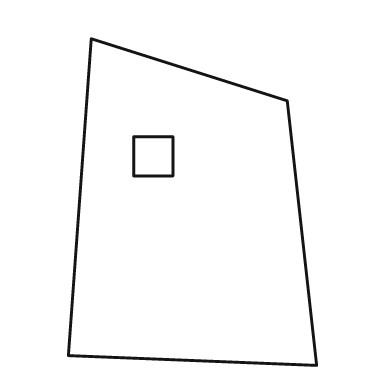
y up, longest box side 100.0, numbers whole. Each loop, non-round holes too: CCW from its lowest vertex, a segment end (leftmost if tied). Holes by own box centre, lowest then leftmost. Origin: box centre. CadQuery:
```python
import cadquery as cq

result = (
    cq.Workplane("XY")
    .moveTo(38.0, -50.0)
    .lineTo(29.0, 31.0)
    .lineTo(-31.0, 50.0)
    .lineTo(-38.0, -47.0)
    .close()
    .moveTo(-18.0, 8.0)
    .lineTo(-6.0, 8.0)
    .lineTo(-6.0, 20.0)
    .lineTo(-18.0, 20.0)
    .close()
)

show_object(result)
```